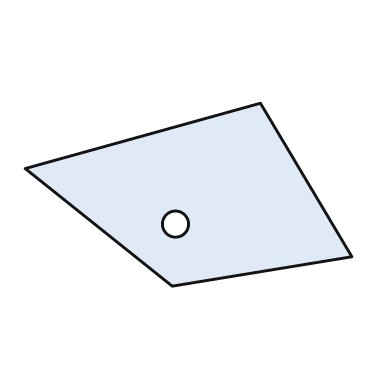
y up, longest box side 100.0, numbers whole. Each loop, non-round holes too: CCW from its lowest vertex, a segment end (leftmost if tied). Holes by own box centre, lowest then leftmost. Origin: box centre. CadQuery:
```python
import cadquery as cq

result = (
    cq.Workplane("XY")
    .moveTo(-5.0, -28.0)
    .lineTo(50.0, -19.0)
    .lineTo(22.0, 28.0)
    .lineTo(-50.0, 8.0)
    .close()
    .moveTo(-4.0, -9.0)
    .circle(4.0)
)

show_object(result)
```